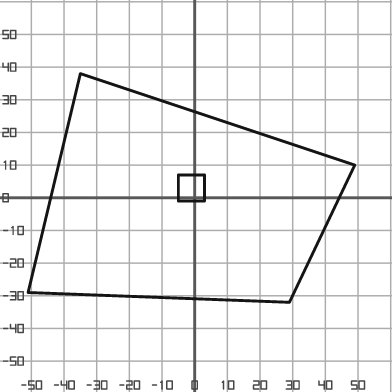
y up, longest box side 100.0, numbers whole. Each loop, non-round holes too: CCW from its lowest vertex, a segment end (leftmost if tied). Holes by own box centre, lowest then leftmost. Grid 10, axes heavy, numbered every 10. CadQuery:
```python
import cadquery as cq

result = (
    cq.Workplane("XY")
    .moveTo(29.0, -32.0)
    .lineTo(49.0, 10.0)
    .lineTo(-35.0, 38.0)
    .lineTo(-51.0, -29.0)
    .close()
    .moveTo(-5.0, -1.0)
    .lineTo(3.0, -1.0)
    .lineTo(3.0, 7.0)
    .lineTo(-5.0, 7.0)
    .close()
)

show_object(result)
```